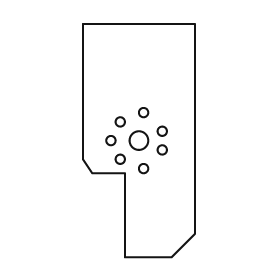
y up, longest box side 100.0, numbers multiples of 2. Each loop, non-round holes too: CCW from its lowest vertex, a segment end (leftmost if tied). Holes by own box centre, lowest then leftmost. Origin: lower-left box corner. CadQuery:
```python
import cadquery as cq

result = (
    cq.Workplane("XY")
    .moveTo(18.0, 0.0)
    .lineTo(38.0, 0.0)
    .lineTo(48.0, 10.0)
    .lineTo(48.0, 100.0)
    .lineTo(0.0, 100.0)
    .lineTo(0.0, 42.0)
    .lineTo(4.0, 36.0)
    .lineTo(18.0, 36.0)
    .close()
    .moveTo(26.0, 38.0)
    .circle(2.0)
    .moveTo(16.0, 42.0)
    .circle(2.0)
    .moveTo(34.0, 46.0)
    .circle(2.0)
    .moveTo(12.0, 50.0)
    .circle(2.0)
    .moveTo(24.0, 50.0)
    .circle(4.0)
    .moveTo(34.0, 54.0)
    .circle(2.0)
    .moveTo(16.0, 58.0)
    .circle(2.0)
    .moveTo(26.0, 62.0)
    .circle(2.0)
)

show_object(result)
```